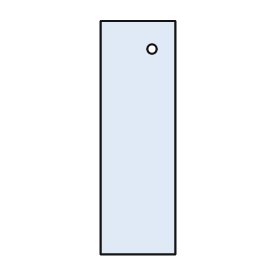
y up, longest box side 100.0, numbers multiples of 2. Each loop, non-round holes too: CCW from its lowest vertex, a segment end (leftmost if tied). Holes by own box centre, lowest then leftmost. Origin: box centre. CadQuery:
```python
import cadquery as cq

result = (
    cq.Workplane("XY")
    .moveTo(-16.0, -50.0)
    .lineTo(16.0, -50.0)
    .lineTo(16.0, 50.0)
    .lineTo(-16.0, 50.0)
    .close()
    .moveTo(6.0, 38.0)
    .circle(2.0)
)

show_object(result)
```